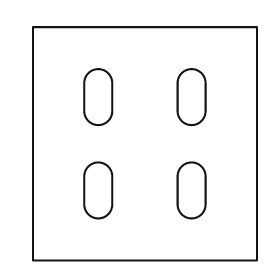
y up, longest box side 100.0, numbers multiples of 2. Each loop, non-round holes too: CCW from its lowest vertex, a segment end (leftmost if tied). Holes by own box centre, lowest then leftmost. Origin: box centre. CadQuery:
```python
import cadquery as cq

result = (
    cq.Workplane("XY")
    .moveTo(-48.0, -50.0)
    .lineTo(48.0, -50.0)
    .lineTo(48.0, 50.0)
    .lineTo(-48.0, 50.0)
    .close()
    .moveTo(-26.0, -26.0)
    .threePointArc((-20.0, -32.0), (-14.0, -26.0))
    .lineTo(-14.0, -14.0)
    .threePointArc((-20.0, -8.0), (-26.0, -14.0))
    .close()
    .moveTo(14.0, -26.0)
    .threePointArc((20.0, -32.0), (26.0, -26.0))
    .lineTo(26.0, -14.0)
    .threePointArc((20.0, -8.0), (14.0, -14.0))
    .close()
    .moveTo(-26.0, 14.0)
    .threePointArc((-20.0, 8.0), (-14.0, 14.0))
    .lineTo(-14.0, 26.0)
    .threePointArc((-20.0, 32.0), (-26.0, 26.0))
    .close()
    .moveTo(14.0, 14.0)
    .threePointArc((20.0, 8.0), (26.0, 14.0))
    .lineTo(26.0, 26.0)
    .threePointArc((20.0, 32.0), (14.0, 26.0))
    .close()
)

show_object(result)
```